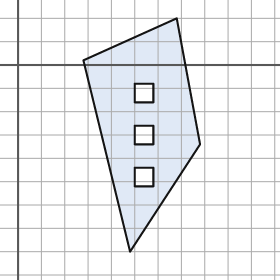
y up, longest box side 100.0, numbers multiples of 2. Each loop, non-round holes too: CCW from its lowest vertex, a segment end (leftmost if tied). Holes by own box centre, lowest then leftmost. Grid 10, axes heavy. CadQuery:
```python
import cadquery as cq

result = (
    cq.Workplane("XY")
    .moveTo(48.0, -80.0)
    .lineTo(78.0, -34.0)
    .lineTo(68.0, 20.0)
    .lineTo(28.0, 2.0)
    .close()
    .moveTo(50.0, -52.0)
    .lineTo(58.0, -52.0)
    .lineTo(58.0, -44.0)
    .lineTo(50.0, -44.0)
    .close()
    .moveTo(50.0, -34.0)
    .lineTo(58.0, -34.0)
    .lineTo(58.0, -26.0)
    .lineTo(50.0, -26.0)
    .close()
    .moveTo(50.0, -16.0)
    .lineTo(58.0, -16.0)
    .lineTo(58.0, -8.0)
    .lineTo(50.0, -8.0)
    .close()
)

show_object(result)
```